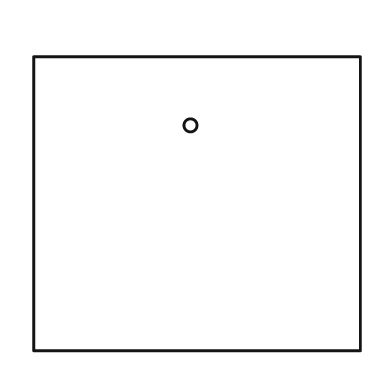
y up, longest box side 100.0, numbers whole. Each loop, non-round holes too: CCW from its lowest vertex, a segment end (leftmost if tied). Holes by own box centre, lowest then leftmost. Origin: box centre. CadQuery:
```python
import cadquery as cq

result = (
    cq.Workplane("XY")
    .moveTo(-50.0, -45.0)
    .lineTo(50.0, -45.0)
    .lineTo(50.0, 45.0)
    .lineTo(-50.0, 45.0)
    .close()
    .moveTo(-2.0, 24.0)
    .circle(2.0)
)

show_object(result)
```